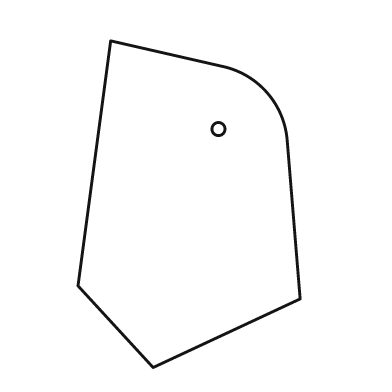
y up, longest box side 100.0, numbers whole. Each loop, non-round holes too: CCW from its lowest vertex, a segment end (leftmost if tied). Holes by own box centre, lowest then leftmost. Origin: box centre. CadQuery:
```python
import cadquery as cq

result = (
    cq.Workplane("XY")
    .moveTo(-11.0, -50.0)
    .lineTo(34.0, -29.0)
    .lineTo(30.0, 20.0)
    .threePointArc((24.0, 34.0), (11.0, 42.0))
    .lineTo(-24.0, 50.0)
    .lineTo(-34.0, -25.0)
    .close()
    .moveTo(9.0, 23.0)
    .circle(2.0)
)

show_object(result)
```